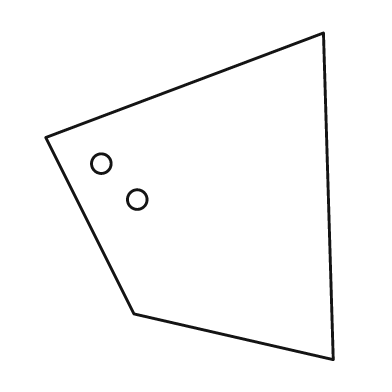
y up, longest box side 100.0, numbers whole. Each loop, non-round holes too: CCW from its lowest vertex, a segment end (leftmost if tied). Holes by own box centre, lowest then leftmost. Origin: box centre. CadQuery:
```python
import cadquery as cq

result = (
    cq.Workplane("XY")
    .moveTo(44.0, -50.0)
    .lineTo(41.0, 50.0)
    .lineTo(-44.0, 18.0)
    .lineTo(-17.0, -36.0)
    .close()
    .moveTo(-16.0, -1.0)
    .circle(3.0)
    .moveTo(-27.0, 10.0)
    .circle(3.0)
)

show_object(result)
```